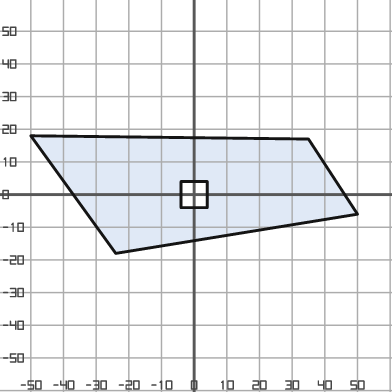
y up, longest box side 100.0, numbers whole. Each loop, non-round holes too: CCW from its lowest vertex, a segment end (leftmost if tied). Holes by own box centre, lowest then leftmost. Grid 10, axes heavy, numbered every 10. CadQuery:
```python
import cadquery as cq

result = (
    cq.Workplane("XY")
    .moveTo(-24.0, -18.0)
    .lineTo(50.0, -6.0)
    .lineTo(35.0, 17.0)
    .lineTo(-50.0, 18.0)
    .close()
    .moveTo(-4.0, -4.0)
    .lineTo(4.0, -4.0)
    .lineTo(4.0, 4.0)
    .lineTo(-4.0, 4.0)
    .close()
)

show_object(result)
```